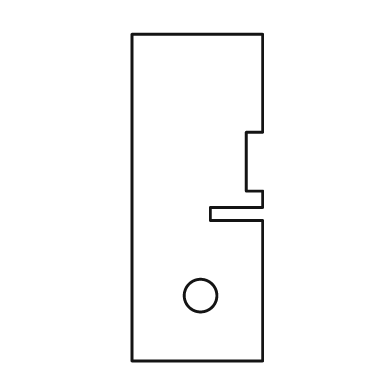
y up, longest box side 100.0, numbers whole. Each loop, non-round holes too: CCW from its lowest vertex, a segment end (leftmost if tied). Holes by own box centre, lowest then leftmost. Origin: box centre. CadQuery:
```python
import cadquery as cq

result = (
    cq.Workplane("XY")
    .moveTo(-20.0, -50.0)
    .lineTo(20.0, -50.0)
    .lineTo(20.0, -7.0)
    .lineTo(4.0, -7.0)
    .lineTo(4.0, -3.0)
    .lineTo(20.0, -3.0)
    .lineTo(20.0, 2.0)
    .lineTo(15.0, 2.0)
    .lineTo(15.0, 20.0)
    .lineTo(20.0, 20.0)
    .lineTo(20.0, 50.0)
    .lineTo(-20.0, 50.0)
    .close()
    .moveTo(1.0, -30.0)
    .circle(5.0)
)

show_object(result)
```